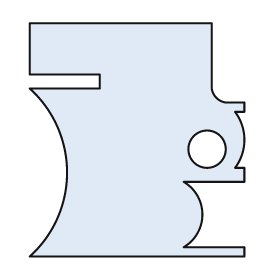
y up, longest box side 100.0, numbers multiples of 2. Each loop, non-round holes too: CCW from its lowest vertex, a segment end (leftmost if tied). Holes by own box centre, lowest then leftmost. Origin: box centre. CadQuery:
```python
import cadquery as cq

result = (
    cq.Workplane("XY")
    .moveTo(-46.0, -50.0)
    .lineTo(46.0, -50.0)
    .lineTo(46.0, -46.0)
    .lineTo(20.0, -46.0)
    .threePointArc((28.0, -32.0), (20.0, -18.0))
    .lineTo(46.0, -18.0)
    .lineTo(46.0, -12.0)
    .lineTo(42.0, -12.0)
    .threePointArc((46.0, 0.0), (42.0, 12.0))
    .lineTo(46.0, 12.0)
    .lineTo(46.0, 16.0)
    .lineTo(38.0, 16.0)
    .threePointArc((34.0, 18.0), (32.0, 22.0))
    .lineTo(32.0, 50.0)
    .lineTo(-46.0, 50.0)
    .lineTo(-46.0, 28.0)
    .lineTo(-16.0, 28.0)
    .lineTo(-16.0, 22.0)
    .lineTo(-46.0, 22.0)
    .threePointArc((-30.0, -14.0), (-46.0, -50.0))
    .close()
    .moveTo(30.0, -4.0)
    .circle(8.0)
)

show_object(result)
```